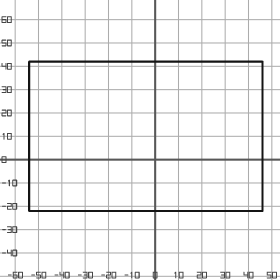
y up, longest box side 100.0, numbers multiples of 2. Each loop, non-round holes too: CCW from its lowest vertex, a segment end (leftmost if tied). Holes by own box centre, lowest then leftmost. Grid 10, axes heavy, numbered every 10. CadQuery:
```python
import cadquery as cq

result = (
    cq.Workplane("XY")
    .moveTo(-54.0, -22.0)
    .lineTo(46.0, -22.0)
    .lineTo(46.0, 42.0)
    .lineTo(-54.0, 42.0)
    .close()
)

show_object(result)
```